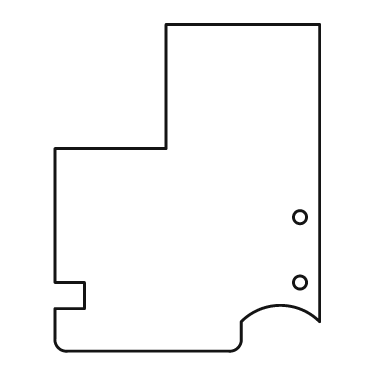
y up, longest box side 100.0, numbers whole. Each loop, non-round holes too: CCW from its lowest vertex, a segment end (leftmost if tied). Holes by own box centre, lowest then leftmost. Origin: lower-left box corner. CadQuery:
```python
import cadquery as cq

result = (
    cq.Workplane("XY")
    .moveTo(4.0, 0.0)
    .lineTo(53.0, 0.0)
    .threePointArc((56.0, 1.0), (57.0, 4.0))
    .lineTo(57.0, 9.0)
    .threePointArc((69.0, 14.0), (81.0, 9.0))
    .lineTo(81.0, 100.0)
    .lineTo(34.0, 100.0)
    .lineTo(34.0, 62.0)
    .lineTo(0.0, 62.0)
    .lineTo(0.0, 21.0)
    .lineTo(9.0, 21.0)
    .lineTo(9.0, 13.0)
    .lineTo(0.0, 13.0)
    .lineTo(0.0, 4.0)
    .threePointArc((1.0, 1.0), (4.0, 0.0))
    .close()
    .moveTo(75.0, 21.0)
    .circle(2.0)
    .moveTo(75.0, 41.0)
    .circle(2.0)
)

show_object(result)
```